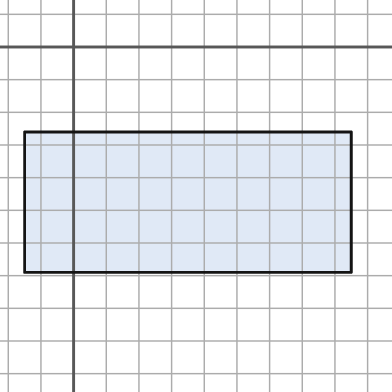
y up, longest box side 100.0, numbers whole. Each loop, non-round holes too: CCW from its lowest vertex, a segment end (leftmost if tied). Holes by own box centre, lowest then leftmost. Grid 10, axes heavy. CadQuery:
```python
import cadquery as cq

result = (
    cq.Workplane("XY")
    .moveTo(-15.0, -69.0)
    .lineTo(85.0, -69.0)
    .lineTo(85.0, -26.0)
    .lineTo(-15.0, -26.0)
    .close()
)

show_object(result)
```